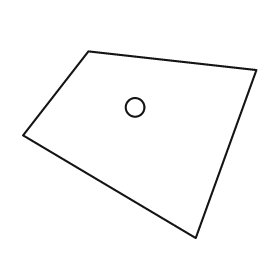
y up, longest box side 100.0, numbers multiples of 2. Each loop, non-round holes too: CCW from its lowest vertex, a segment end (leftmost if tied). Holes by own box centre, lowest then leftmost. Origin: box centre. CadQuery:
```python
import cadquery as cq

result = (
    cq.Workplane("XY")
    .moveTo(24.0, -40.0)
    .lineTo(50.0, 32.0)
    .lineTo(-22.0, 40.0)
    .lineTo(-50.0, 4.0)
    .close()
    .moveTo(-2.0, 16.0)
    .circle(4.0)
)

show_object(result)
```